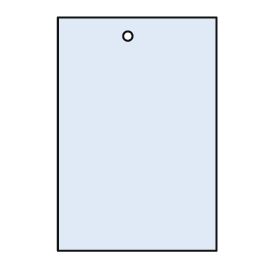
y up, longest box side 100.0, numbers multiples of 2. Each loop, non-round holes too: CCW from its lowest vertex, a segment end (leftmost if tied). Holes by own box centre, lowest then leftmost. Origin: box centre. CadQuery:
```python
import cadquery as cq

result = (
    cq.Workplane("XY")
    .moveTo(-34.0, -50.0)
    .lineTo(34.0, -50.0)
    .lineTo(34.0, 50.0)
    .lineTo(-34.0, 50.0)
    .close()
    .moveTo(-4.0, 42.0)
    .circle(2.0)
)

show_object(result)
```